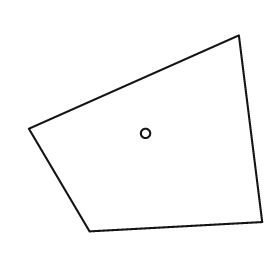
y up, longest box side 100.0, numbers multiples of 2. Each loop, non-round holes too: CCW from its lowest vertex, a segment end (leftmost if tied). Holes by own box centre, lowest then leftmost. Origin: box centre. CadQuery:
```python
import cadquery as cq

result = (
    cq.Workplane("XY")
    .moveTo(-24.0, -42.0)
    .lineTo(50.0, -38.0)
    .lineTo(40.0, 42.0)
    .lineTo(-50.0, 2.0)
    .close()
    .moveTo(0.0, 0.0)
    .circle(2.0)
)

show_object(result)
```